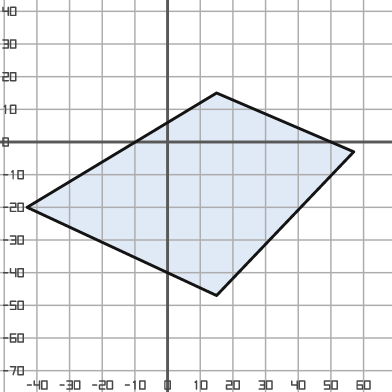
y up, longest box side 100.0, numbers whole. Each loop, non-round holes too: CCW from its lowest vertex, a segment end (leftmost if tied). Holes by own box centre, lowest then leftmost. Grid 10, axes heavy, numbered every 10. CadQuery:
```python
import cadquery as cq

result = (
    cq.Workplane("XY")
    .moveTo(15.0, -47.0)
    .lineTo(57.0, -3.0)
    .lineTo(15.0, 15.0)
    .lineTo(-43.0, -20.0)
    .close()
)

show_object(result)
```